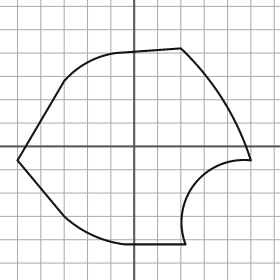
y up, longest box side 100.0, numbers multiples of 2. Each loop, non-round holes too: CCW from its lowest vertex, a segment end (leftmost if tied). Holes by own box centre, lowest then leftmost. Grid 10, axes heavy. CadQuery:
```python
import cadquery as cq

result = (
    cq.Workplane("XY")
    .moveTo(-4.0, -42.0)
    .lineTo(22.0, -42.0)
    .threePointArc((26.0, -16.0), (50.0, -6.0))
    .threePointArc((38.0, 20.0), (20.0, 42.0))
    .lineTo(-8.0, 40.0)
    .threePointArc((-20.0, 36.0), (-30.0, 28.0))
    .lineTo(-50.0, -6.0)
    .lineTo(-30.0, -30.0)
    .threePointArc((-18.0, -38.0), (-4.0, -42.0))
    .close()
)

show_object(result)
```